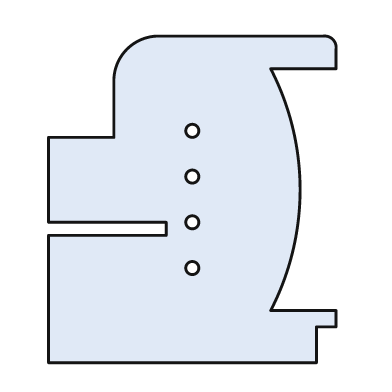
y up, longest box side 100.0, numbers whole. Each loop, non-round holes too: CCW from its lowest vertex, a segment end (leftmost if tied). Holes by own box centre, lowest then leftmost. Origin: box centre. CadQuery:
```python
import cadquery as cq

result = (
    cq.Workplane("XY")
    .moveTo(-44.0, -50.0)
    .lineTo(38.0, -50.0)
    .lineTo(38.0, -39.0)
    .lineTo(44.0, -39.0)
    .lineTo(44.0, -34.0)
    .lineTo(24.0, -34.0)
    .threePointArc((33.0, 3.0), (24.0, 40.0))
    .lineTo(44.0, 40.0)
    .lineTo(44.0, 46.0)
    .threePointArc((43.0, 49.0), (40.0, 50.0))
    .lineTo(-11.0, 50.0)
    .threePointArc((-20.0, 46.0), (-24.0, 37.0))
    .lineTo(-24.0, 19.0)
    .lineTo(-44.0, 19.0)
    .lineTo(-44.0, -7.0)
    .lineTo(-8.0, -7.0)
    .lineTo(-8.0, -11.0)
    .lineTo(-44.0, -11.0)
    .close()
    .moveTo(0.0, -21.0)
    .circle(2.0)
    .moveTo(0.0, -7.0)
    .circle(2.0)
    .moveTo(0.0, 7.0)
    .circle(2.0)
    .moveTo(0.0, 21.0)
    .circle(2.0)
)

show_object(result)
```